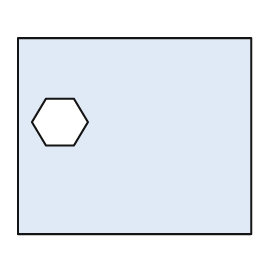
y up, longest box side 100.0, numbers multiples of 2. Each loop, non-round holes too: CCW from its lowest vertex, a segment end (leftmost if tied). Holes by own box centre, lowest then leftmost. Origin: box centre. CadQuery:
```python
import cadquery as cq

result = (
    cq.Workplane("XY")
    .moveTo(-50.0, -42.0)
    .lineTo(50.0, -42.0)
    .lineTo(50.0, 42.0)
    .lineTo(-50.0, 42.0)
    .close()
    .moveTo(-38.0, -4.0)
    .lineTo(-26.0, -4.0)
    .lineTo(-20.0, 6.0)
    .lineTo(-26.0, 16.0)
    .lineTo(-38.0, 16.0)
    .lineTo(-44.0, 6.0)
    .close()
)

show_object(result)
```